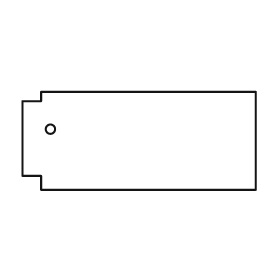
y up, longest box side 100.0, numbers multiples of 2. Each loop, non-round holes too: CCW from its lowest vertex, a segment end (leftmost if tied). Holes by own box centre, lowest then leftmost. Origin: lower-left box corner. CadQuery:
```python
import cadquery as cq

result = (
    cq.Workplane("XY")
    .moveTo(8.0, 0.0)
    .lineTo(100.0, 0.0)
    .lineTo(100.0, 42.0)
    .lineTo(8.0, 42.0)
    .lineTo(8.0, 38.0)
    .lineTo(0.0, 38.0)
    .lineTo(0.0, 6.0)
    .lineTo(8.0, 6.0)
    .close()
    .moveTo(12.0, 26.0)
    .circle(2.0)
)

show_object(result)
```